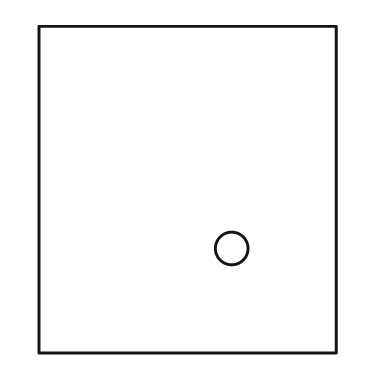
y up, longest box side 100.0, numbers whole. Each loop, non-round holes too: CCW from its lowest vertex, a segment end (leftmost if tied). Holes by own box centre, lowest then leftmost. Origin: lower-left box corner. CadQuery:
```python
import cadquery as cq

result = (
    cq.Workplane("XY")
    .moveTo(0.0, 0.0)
    .lineTo(91.0, 0.0)
    .lineTo(91.0, 100.0)
    .lineTo(0.0, 100.0)
    .close()
    .moveTo(59.0, 32.0)
    .circle(5.0)
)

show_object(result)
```